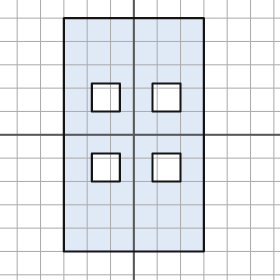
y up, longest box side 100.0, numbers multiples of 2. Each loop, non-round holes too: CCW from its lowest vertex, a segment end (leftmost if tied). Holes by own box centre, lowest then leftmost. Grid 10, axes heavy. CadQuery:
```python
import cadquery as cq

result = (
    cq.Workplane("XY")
    .moveTo(-30.0, -50.0)
    .lineTo(30.0, -50.0)
    .lineTo(30.0, 50.0)
    .lineTo(-30.0, 50.0)
    .close()
    .moveTo(-18.0, -20.0)
    .lineTo(-6.0, -20.0)
    .lineTo(-6.0, -8.0)
    .lineTo(-18.0, -8.0)
    .close()
    .moveTo(8.0, -20.0)
    .lineTo(20.0, -20.0)
    .lineTo(20.0, -8.0)
    .lineTo(8.0, -8.0)
    .close()
    .moveTo(-18.0, 10.0)
    .lineTo(-6.0, 10.0)
    .lineTo(-6.0, 22.0)
    .lineTo(-18.0, 22.0)
    .close()
    .moveTo(8.0, 10.0)
    .lineTo(20.0, 10.0)
    .lineTo(20.0, 22.0)
    .lineTo(8.0, 22.0)
    .close()
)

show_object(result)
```